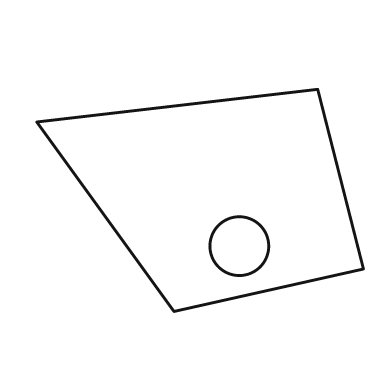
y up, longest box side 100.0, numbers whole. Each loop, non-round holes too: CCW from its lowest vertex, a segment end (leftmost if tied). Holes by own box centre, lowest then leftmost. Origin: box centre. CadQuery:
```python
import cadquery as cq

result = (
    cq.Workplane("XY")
    .moveTo(-8.0, -34.0)
    .lineTo(50.0, -21.0)
    .lineTo(36.0, 34.0)
    .lineTo(-50.0, 24.0)
    .close()
    .moveTo(12.0, -14.0)
    .circle(9.0)
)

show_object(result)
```